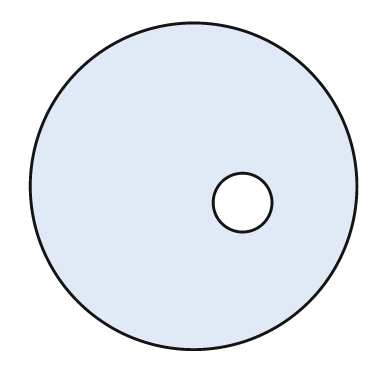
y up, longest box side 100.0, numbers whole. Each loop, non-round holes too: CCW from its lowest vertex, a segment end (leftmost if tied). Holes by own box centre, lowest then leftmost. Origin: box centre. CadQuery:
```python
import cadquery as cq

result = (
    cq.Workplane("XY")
    .moveTo(0.0, 0.0)
    .circle(50.0)
    .moveTo(15.0, -5.0)
    .circle(9.0)
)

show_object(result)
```